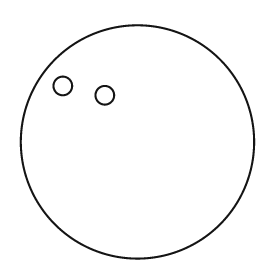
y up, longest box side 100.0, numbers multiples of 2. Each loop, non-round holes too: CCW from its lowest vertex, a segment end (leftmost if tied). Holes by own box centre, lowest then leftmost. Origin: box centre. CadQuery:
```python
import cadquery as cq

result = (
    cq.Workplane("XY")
    .moveTo(0.0, 0.0)
    .circle(50.0)
    .moveTo(-14.0, 20.0)
    .circle(4.0)
    .moveTo(-32.0, 24.0)
    .circle(4.0)
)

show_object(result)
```